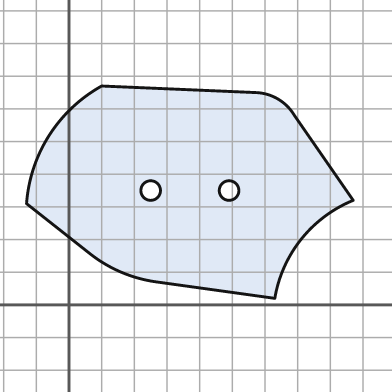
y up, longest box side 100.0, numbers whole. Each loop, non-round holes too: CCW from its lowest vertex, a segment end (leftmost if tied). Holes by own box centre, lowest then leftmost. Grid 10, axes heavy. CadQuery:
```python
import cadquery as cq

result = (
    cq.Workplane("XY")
    .moveTo(63.0, 2.0)
    .threePointArc((71.0, 20.0), (87.0, 32.0))
    .lineTo(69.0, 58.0)
    .threePointArc((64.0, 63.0), (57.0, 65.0))
    .lineTo(10.0, 67.0)
    .threePointArc((-6.0, 52.0), (-13.0, 31.0))
    .lineTo(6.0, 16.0)
    .threePointArc((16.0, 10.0), (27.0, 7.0))
    .close()
    .moveTo(25.0, 35.0)
    .circle(3.0)
    .moveTo(49.0, 35.0)
    .circle(3.0)
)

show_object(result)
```